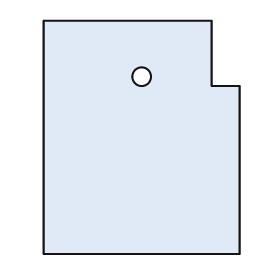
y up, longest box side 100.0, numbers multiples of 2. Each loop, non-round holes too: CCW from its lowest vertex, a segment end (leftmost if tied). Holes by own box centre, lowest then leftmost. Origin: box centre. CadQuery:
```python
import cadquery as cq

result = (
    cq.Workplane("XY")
    .moveTo(-42.0, -50.0)
    .lineTo(42.0, -50.0)
    .lineTo(42.0, 22.0)
    .lineTo(30.0, 22.0)
    .lineTo(30.0, 50.0)
    .lineTo(-42.0, 50.0)
    .close()
    .moveTo(0.0, 26.0)
    .circle(4.0)
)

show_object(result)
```